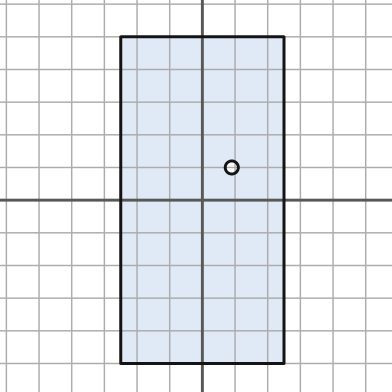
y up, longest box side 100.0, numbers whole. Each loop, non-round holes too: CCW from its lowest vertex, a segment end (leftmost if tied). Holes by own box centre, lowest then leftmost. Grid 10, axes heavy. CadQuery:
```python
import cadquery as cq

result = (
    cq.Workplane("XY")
    .moveTo(-25.0, -50.0)
    .lineTo(25.0, -50.0)
    .lineTo(25.0, 50.0)
    .lineTo(-25.0, 50.0)
    .close()
    .moveTo(9.0, 10.0)
    .circle(2.0)
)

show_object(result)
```